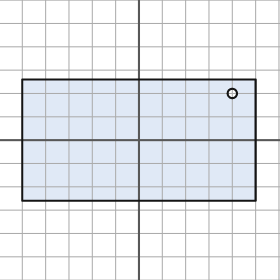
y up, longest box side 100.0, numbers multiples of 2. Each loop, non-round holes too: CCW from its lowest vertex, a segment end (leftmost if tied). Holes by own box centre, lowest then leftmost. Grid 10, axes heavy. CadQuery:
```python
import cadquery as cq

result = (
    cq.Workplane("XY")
    .moveTo(-50.0, -26.0)
    .lineTo(50.0, -26.0)
    .lineTo(50.0, 26.0)
    .lineTo(-50.0, 26.0)
    .close()
    .moveTo(40.0, 20.0)
    .circle(2.0)
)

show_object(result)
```